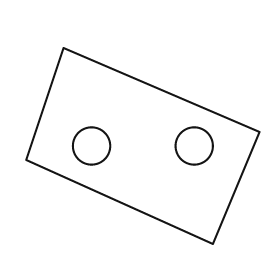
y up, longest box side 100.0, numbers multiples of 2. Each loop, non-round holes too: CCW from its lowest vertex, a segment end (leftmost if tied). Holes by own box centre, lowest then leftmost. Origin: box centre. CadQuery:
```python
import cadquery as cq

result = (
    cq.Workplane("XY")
    .moveTo(30.0, -42.0)
    .lineTo(50.0, 6.0)
    .lineTo(-34.0, 42.0)
    .lineTo(-50.0, -6.0)
    .close()
    .moveTo(-22.0, 0.0)
    .circle(8.0)
    .moveTo(22.0, 0.0)
    .circle(8.0)
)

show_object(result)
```